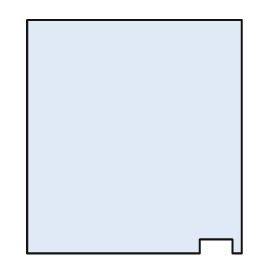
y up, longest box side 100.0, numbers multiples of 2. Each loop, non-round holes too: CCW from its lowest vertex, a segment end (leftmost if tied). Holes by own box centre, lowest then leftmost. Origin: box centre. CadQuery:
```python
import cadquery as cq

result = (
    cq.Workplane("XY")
    .moveTo(-46.0, -50.0)
    .lineTo(28.0, -50.0)
    .lineTo(28.0, -44.0)
    .lineTo(42.0, -44.0)
    .lineTo(42.0, -50.0)
    .lineTo(46.0, -50.0)
    .lineTo(46.0, 50.0)
    .lineTo(-46.0, 50.0)
    .close()
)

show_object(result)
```